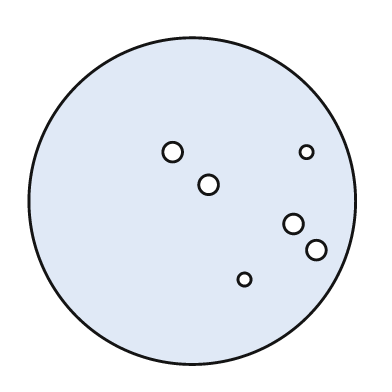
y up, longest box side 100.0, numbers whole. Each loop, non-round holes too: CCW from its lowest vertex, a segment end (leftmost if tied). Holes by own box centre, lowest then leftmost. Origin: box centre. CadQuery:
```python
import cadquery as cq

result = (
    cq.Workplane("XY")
    .moveTo(0.0, 0.0)
    .circle(50.0)
    .moveTo(16.0, -24.0)
    .circle(2.0)
    .moveTo(38.0, -15.0)
    .circle(3.0)
    .moveTo(31.0, -7.0)
    .circle(3.0)
    .moveTo(5.0, 5.0)
    .circle(3.0)
    .moveTo(-6.0, 15.0)
    .circle(3.0)
    .moveTo(35.0, 15.0)
    .circle(2.0)
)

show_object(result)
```